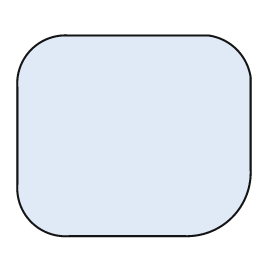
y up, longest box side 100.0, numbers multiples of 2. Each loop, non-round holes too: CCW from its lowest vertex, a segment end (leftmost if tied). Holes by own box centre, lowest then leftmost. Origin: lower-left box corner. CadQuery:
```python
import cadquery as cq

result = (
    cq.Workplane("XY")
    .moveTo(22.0, 0.0)
    .lineTo(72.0, 0.0)
    .threePointArc((92.0, 8.0), (100.0, 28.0))
    .lineTo(100.0, 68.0)
    .threePointArc((94.0, 80.0), (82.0, 86.0))
    .lineTo(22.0, 86.0)
    .threePointArc((6.0, 80.0), (0.0, 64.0))
    .lineTo(0.0, 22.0)
    .threePointArc((6.0, 6.0), (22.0, 0.0))
    .close()
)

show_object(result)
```